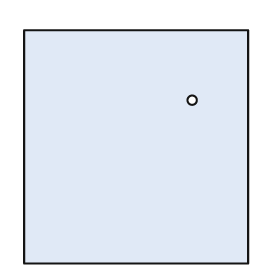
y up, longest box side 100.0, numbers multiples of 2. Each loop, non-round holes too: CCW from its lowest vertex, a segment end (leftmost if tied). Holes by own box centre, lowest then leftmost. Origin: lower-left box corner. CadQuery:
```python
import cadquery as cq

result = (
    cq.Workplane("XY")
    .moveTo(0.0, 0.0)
    .lineTo(96.0, 0.0)
    .lineTo(96.0, 100.0)
    .lineTo(0.0, 100.0)
    .close()
    .moveTo(72.0, 70.0)
    .circle(2.0)
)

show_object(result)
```